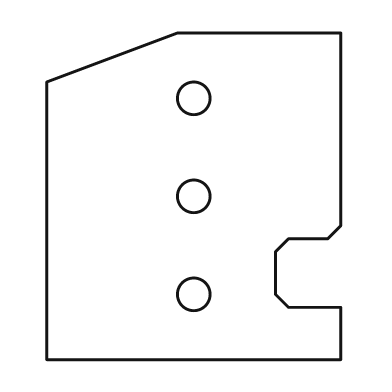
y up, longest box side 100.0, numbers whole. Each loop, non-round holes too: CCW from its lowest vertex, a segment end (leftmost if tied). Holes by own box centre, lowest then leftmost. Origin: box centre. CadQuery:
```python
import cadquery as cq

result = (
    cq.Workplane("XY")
    .moveTo(-45.0, -50.0)
    .lineTo(45.0, -50.0)
    .lineTo(45.0, -34.0)
    .lineTo(29.0, -34.0)
    .lineTo(25.0, -30.0)
    .lineTo(25.0, -17.0)
    .lineTo(29.0, -13.0)
    .lineTo(41.0, -13.0)
    .lineTo(45.0, -9.0)
    .lineTo(45.0, 50.0)
    .lineTo(-5.0, 50.0)
    .lineTo(-45.0, 35.0)
    .close()
    .moveTo(0.0, -30.0)
    .circle(5.0)
    .moveTo(0.0, 0.0)
    .circle(5.0)
    .moveTo(0.0, 30.0)
    .circle(5.0)
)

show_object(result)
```